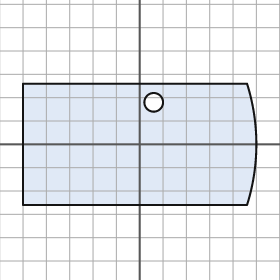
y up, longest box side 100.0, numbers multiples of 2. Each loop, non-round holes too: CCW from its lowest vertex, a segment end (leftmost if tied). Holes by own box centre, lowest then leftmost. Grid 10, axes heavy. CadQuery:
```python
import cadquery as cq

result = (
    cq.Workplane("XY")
    .moveTo(-50.0, -26.0)
    .lineTo(46.0, -26.0)
    .threePointArc((50.0, 0.0), (46.0, 26.0))
    .lineTo(-50.0, 26.0)
    .close()
    .moveTo(6.0, 18.0)
    .circle(4.0)
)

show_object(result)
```